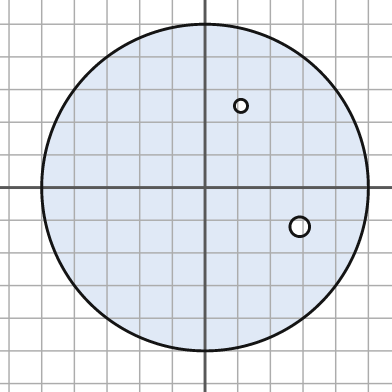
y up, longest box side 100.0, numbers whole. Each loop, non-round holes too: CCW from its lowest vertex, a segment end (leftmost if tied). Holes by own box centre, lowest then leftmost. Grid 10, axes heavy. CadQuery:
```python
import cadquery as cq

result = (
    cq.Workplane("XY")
    .moveTo(0.0, 0.0)
    .circle(50.0)
    .moveTo(29.0, -12.0)
    .circle(3.0)
    .moveTo(11.0, 25.0)
    .circle(2.0)
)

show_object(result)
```